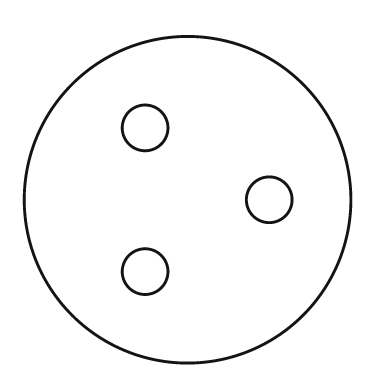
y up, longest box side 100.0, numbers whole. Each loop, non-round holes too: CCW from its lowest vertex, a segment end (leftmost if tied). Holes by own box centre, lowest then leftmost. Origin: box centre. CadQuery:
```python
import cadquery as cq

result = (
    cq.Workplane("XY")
    .moveTo(0.0, 0.0)
    .circle(50.0)
    .moveTo(-13.0, -22.0)
    .circle(7.0)
    .moveTo(25.0, 0.0)
    .circle(7.0)
    .moveTo(-13.0, 22.0)
    .circle(7.0)
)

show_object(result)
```